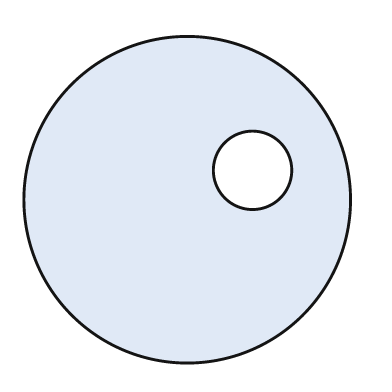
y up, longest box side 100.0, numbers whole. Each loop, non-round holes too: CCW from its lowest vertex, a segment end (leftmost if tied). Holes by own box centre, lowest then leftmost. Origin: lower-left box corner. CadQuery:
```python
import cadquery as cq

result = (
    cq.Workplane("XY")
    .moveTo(50.0, 50.0)
    .circle(50.0)
    .moveTo(70.0, 59.0)
    .circle(12.0)
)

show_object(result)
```